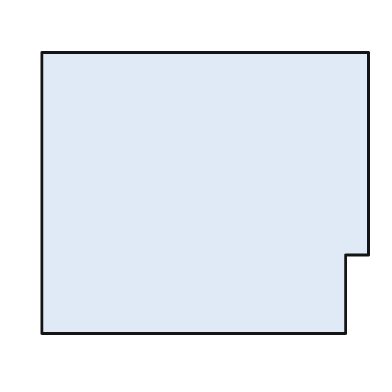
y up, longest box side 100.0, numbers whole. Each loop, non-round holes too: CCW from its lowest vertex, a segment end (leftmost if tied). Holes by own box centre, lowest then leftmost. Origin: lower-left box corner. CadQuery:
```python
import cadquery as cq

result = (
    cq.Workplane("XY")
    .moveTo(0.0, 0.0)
    .lineTo(93.0, 0.0)
    .lineTo(93.0, 24.0)
    .lineTo(100.0, 24.0)
    .lineTo(100.0, 86.0)
    .lineTo(0.0, 86.0)
    .close()
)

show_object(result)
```